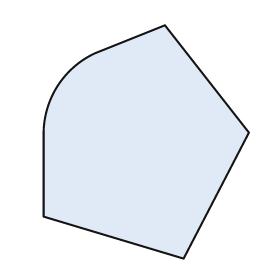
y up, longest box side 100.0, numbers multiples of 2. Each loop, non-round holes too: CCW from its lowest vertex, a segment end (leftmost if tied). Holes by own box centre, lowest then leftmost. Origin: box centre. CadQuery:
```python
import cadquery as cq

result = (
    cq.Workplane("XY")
    .moveTo(16.0, -50.0)
    .lineTo(44.0, 4.0)
    .lineTo(8.0, 50.0)
    .lineTo(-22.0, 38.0)
    .threePointArc((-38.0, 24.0), (-44.0, 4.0))
    .lineTo(-44.0, -32.0)
    .close()
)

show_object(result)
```